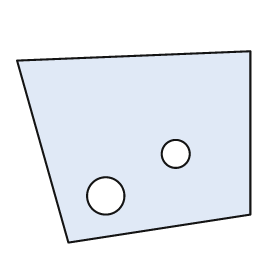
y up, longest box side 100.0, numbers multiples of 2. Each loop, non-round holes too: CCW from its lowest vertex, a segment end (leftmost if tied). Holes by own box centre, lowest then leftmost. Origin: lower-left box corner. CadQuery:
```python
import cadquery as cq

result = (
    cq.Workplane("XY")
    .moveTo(22.0, 0.0)
    .lineTo(100.0, 12.0)
    .lineTo(100.0, 82.0)
    .lineTo(0.0, 78.0)
    .close()
    .moveTo(38.0, 20.0)
    .circle(8.0)
    .moveTo(68.0, 38.0)
    .circle(6.0)
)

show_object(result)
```